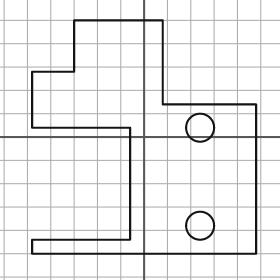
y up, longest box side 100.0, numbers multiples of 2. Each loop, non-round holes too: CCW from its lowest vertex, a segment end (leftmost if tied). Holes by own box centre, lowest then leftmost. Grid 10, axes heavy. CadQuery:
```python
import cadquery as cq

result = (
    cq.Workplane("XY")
    .moveTo(-48.0, -50.0)
    .lineTo(48.0, -50.0)
    .lineTo(48.0, 14.0)
    .lineTo(8.0, 14.0)
    .lineTo(8.0, 50.0)
    .lineTo(-30.0, 50.0)
    .lineTo(-30.0, 28.0)
    .lineTo(-48.0, 28.0)
    .lineTo(-48.0, 4.0)
    .lineTo(-6.0, 4.0)
    .lineTo(-6.0, -44.0)
    .lineTo(-48.0, -44.0)
    .close()
    .moveTo(24.0, -38.0)
    .circle(6.0)
    .moveTo(24.0, 4.0)
    .circle(6.0)
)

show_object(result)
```